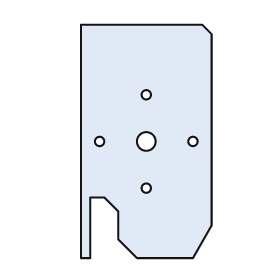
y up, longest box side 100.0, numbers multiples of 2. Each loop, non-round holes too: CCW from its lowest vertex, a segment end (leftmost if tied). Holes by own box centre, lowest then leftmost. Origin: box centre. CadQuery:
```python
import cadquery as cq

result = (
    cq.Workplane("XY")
    .moveTo(-28.0, -50.0)
    .lineTo(-24.0, -50.0)
    .lineTo(-24.0, -24.0)
    .lineTo(-18.0, -24.0)
    .lineTo(-12.0, -30.0)
    .lineTo(-12.0, -42.0)
    .lineTo(-4.0, -50.0)
    .lineTo(20.0, -50.0)
    .lineTo(28.0, -36.0)
    .lineTo(28.0, 46.0)
    .lineTo(24.0, 50.0)
    .lineTo(-28.0, 50.0)
    .close()
    .moveTo(0.0, -20.0)
    .circle(2.0)
    .moveTo(-20.0, 0.0)
    .circle(2.0)
    .moveTo(0.0, 0.0)
    .circle(4.0)
    .moveTo(20.0, 0.0)
    .circle(2.0)
    .moveTo(0.0, 20.0)
    .circle(2.0)
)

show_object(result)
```